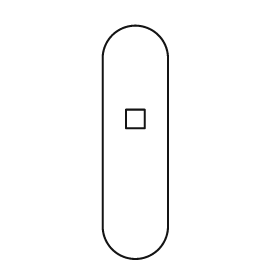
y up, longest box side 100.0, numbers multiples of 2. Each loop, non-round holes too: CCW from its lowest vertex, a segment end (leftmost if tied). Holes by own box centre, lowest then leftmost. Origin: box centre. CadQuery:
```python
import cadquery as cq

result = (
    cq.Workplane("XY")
    .moveTo(-14.0, -36.0)
    .threePointArc((0.0, -50.0), (14.0, -36.0))
    .lineTo(14.0, 36.0)
    .threePointArc((0.0, 50.0), (-14.0, 36.0))
    .close()
    .moveTo(-4.0, 6.0)
    .lineTo(4.0, 6.0)
    .lineTo(4.0, 14.0)
    .lineTo(-4.0, 14.0)
    .close()
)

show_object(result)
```